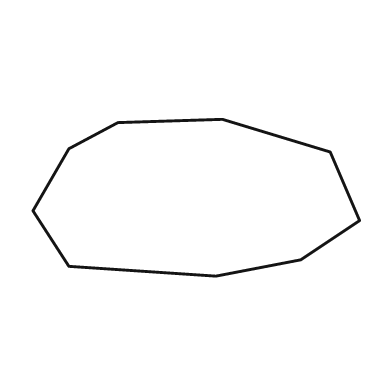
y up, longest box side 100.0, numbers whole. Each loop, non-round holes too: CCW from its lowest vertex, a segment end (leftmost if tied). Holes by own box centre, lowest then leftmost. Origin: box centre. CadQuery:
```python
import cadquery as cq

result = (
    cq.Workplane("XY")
    .moveTo(6.0, -24.0)
    .lineTo(32.0, -19.0)
    .lineTo(50.0, -7.0)
    .lineTo(41.0, 14.0)
    .lineTo(8.0, 24.0)
    .lineTo(-24.0, 23.0)
    .lineTo(-39.0, 15.0)
    .lineTo(-50.0, -4.0)
    .lineTo(-39.0, -21.0)
    .close()
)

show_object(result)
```